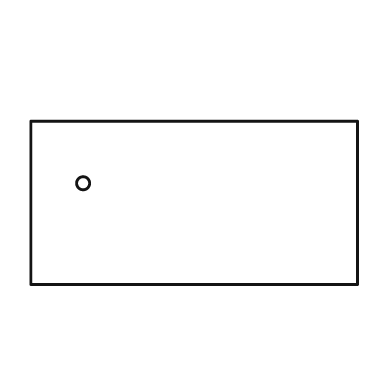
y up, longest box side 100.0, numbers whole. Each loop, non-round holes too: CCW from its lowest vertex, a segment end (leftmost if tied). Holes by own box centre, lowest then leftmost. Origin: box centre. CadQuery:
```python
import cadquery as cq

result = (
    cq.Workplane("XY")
    .moveTo(-50.0, -25.0)
    .lineTo(50.0, -25.0)
    .lineTo(50.0, 25.0)
    .lineTo(-50.0, 25.0)
    .close()
    .moveTo(-34.0, 6.0)
    .circle(2.0)
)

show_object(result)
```